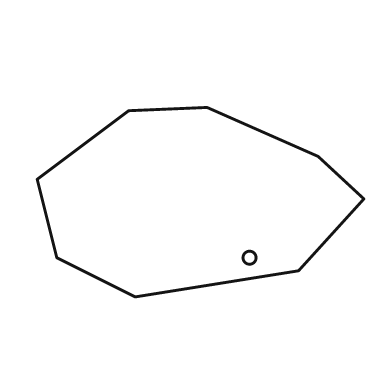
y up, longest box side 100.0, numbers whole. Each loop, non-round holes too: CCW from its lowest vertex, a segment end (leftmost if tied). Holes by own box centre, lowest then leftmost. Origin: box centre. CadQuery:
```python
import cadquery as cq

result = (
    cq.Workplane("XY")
    .moveTo(-20.0, -29.0)
    .lineTo(30.0, -21.0)
    .lineTo(50.0, 1.0)
    .lineTo(36.0, 14.0)
    .lineTo(2.0, 29.0)
    .lineTo(-22.0, 28.0)
    .lineTo(-50.0, 7.0)
    .lineTo(-44.0, -17.0)
    .close()
    .moveTo(15.0, -17.0)
    .circle(2.0)
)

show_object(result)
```